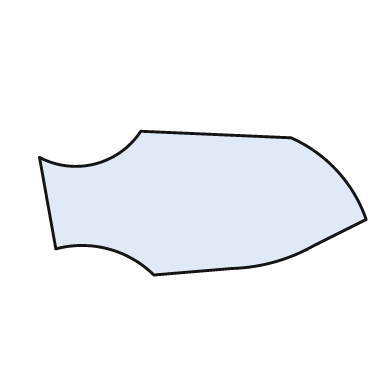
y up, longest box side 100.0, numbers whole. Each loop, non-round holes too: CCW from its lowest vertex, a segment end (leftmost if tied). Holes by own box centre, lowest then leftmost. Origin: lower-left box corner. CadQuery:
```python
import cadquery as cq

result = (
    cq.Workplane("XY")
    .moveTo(35.0, 0.0)
    .lineTo(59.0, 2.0)
    .threePointArc((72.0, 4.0), (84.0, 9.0))
    .lineTo(100.0, 17.0)
    .threePointArc((91.0, 32.0), (77.0, 42.0))
    .lineTo(31.0, 44.0)
    .threePointArc((17.0, 34.0), (0.0, 36.0))
    .lineTo(5.0, 8.0)
    .threePointArc((21.0, 8.0), (35.0, 0.0))
    .close()
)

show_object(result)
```